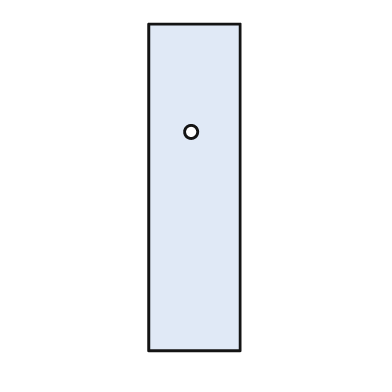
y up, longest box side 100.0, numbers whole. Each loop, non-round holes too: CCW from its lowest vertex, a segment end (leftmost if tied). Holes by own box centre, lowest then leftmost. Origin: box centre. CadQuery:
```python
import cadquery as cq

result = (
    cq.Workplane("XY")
    .moveTo(-14.0, -50.0)
    .lineTo(14.0, -50.0)
    .lineTo(14.0, 50.0)
    .lineTo(-14.0, 50.0)
    .close()
    .moveTo(-1.0, 17.0)
    .circle(2.0)
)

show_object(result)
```